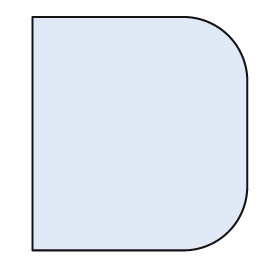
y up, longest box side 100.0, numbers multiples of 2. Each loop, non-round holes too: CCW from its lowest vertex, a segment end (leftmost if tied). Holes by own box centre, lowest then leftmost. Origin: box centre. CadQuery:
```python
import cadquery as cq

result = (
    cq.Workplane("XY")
    .moveTo(-46.0, -50.0)
    .lineTo(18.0, -50.0)
    .threePointArc((38.0, -42.0), (46.0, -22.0))
    .lineTo(46.0, 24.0)
    .threePointArc((38.0, 42.0), (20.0, 50.0))
    .lineTo(-46.0, 50.0)
    .close()
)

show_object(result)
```